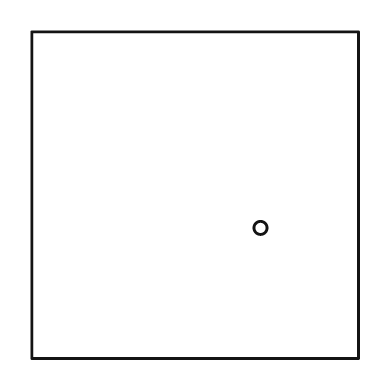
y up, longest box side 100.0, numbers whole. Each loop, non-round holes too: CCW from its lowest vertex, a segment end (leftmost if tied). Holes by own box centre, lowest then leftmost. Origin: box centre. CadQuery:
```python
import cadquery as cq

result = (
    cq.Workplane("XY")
    .moveTo(-50.0, -50.0)
    .lineTo(50.0, -50.0)
    .lineTo(50.0, 50.0)
    .lineTo(-50.0, 50.0)
    .close()
    .moveTo(20.0, -10.0)
    .circle(2.0)
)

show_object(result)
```